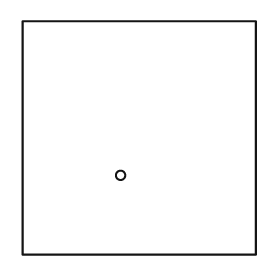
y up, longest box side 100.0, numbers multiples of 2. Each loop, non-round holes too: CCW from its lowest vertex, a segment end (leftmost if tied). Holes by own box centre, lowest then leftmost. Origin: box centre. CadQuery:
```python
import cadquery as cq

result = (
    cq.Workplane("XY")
    .moveTo(-50.0, -50.0)
    .lineTo(50.0, -50.0)
    .lineTo(50.0, 50.0)
    .lineTo(-50.0, 50.0)
    .close()
    .moveTo(-8.0, -16.0)
    .circle(2.0)
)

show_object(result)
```